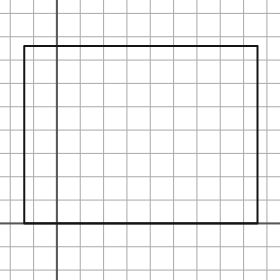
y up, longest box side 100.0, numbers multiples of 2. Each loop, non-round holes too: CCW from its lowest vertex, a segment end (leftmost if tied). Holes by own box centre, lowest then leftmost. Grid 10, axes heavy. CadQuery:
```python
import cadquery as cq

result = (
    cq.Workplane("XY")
    .moveTo(-14.0, 0.0)
    .lineTo(86.0, 0.0)
    .lineTo(86.0, 76.0)
    .lineTo(-14.0, 76.0)
    .close()
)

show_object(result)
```